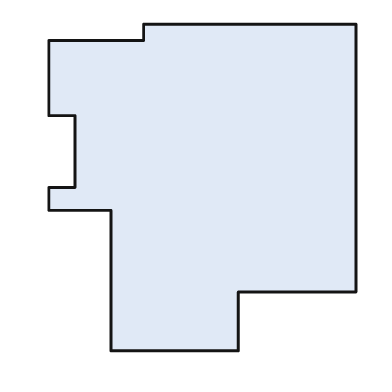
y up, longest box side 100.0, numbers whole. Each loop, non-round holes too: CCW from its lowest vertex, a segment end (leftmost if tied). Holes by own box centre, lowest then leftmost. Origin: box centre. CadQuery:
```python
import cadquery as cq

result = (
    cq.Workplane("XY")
    .moveTo(-28.0, -50.0)
    .lineTo(11.0, -50.0)
    .lineTo(11.0, -32.0)
    .lineTo(47.0, -32.0)
    .lineTo(47.0, 50.0)
    .lineTo(-18.0, 50.0)
    .lineTo(-18.0, 45.0)
    .lineTo(-47.0, 45.0)
    .lineTo(-47.0, 22.0)
    .lineTo(-39.0, 22.0)
    .lineTo(-39.0, 0.0)
    .lineTo(-47.0, 0.0)
    .lineTo(-47.0, -7.0)
    .lineTo(-28.0, -7.0)
    .close()
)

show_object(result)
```